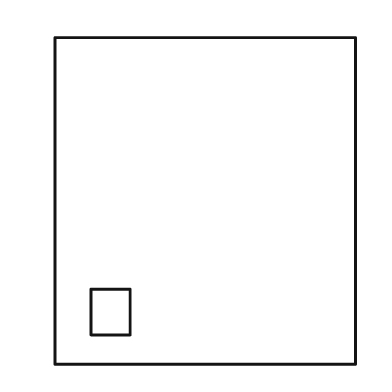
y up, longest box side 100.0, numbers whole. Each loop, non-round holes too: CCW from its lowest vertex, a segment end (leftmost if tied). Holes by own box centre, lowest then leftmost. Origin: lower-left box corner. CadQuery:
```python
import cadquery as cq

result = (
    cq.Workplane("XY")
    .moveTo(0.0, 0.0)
    .lineTo(92.0, 0.0)
    .lineTo(92.0, 100.0)
    .lineTo(0.0, 100.0)
    .close()
    .moveTo(11.0, 9.0)
    .lineTo(23.0, 9.0)
    .lineTo(23.0, 23.0)
    .lineTo(11.0, 23.0)
    .close()
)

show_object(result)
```